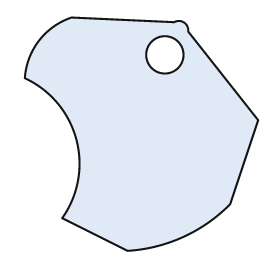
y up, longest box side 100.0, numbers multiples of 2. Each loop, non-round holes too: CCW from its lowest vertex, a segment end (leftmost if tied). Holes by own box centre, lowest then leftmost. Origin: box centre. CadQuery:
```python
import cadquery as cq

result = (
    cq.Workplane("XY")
    .moveTo(-6.0, -50.0)
    .threePointArc((18.0, -44.0), (38.0, -30.0))
    .lineTo(50.0, 6.0)
    .lineTo(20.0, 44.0)
    .threePointArc((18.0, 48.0), (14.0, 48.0))
    .lineTo(-30.0, 50.0)
    .threePointArc((-44.0, 40.0), (-50.0, 24.0))
    .threePointArc((-28.0, -2.0), (-34.0, -36.0))
    .close()
    .moveTo(10.0, 34.0)
    .circle(8.0)
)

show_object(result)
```